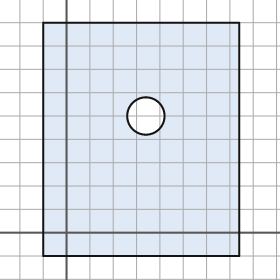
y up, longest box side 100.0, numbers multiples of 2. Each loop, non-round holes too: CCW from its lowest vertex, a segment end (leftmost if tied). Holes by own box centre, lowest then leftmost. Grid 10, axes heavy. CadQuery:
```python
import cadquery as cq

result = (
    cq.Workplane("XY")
    .moveTo(-10.0, -10.0)
    .lineTo(74.0, -10.0)
    .lineTo(74.0, 90.0)
    .lineTo(-10.0, 90.0)
    .close()
    .moveTo(34.0, 50.0)
    .circle(8.0)
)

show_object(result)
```